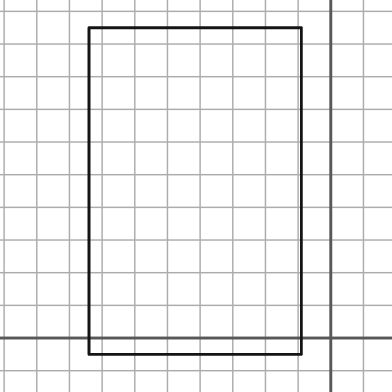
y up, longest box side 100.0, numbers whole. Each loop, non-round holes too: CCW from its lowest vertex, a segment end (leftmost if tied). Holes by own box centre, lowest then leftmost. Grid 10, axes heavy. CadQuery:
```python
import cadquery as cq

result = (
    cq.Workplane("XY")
    .moveTo(-74.0, -5.0)
    .lineTo(-9.0, -5.0)
    .lineTo(-9.0, 95.0)
    .lineTo(-74.0, 95.0)
    .close()
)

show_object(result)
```